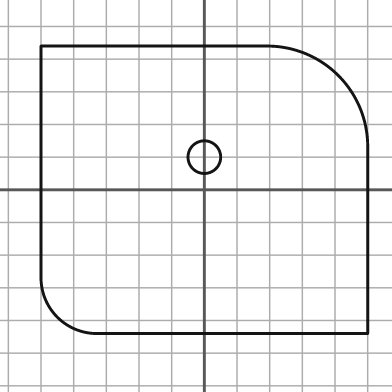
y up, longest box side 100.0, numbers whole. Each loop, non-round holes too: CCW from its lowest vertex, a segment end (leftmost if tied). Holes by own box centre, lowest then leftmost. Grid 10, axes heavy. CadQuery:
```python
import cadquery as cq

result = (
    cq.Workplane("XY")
    .moveTo(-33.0, -44.0)
    .lineTo(50.0, -44.0)
    .lineTo(50.0, 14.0)
    .threePointArc((41.0, 35.0), (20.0, 44.0))
    .lineTo(-50.0, 44.0)
    .lineTo(-50.0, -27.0)
    .threePointArc((-45.0, -39.0), (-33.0, -44.0))
    .close()
    .moveTo(0.0, 10.0)
    .circle(5.0)
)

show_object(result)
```